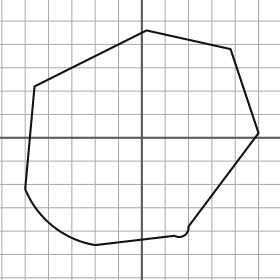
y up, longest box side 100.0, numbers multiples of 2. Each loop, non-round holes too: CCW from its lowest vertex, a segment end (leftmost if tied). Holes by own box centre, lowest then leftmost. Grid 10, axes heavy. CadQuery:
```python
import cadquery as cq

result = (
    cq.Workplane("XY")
    .moveTo(-20.0, -46.0)
    .lineTo(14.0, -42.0)
    .threePointArc((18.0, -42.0), (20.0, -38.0))
    .lineTo(50.0, 2.0)
    .lineTo(38.0, 38.0)
    .lineTo(2.0, 46.0)
    .lineTo(-46.0, 22.0)
    .lineTo(-50.0, -22.0)
    .threePointArc((-38.0, -38.0), (-20.0, -46.0))
    .close()
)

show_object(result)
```